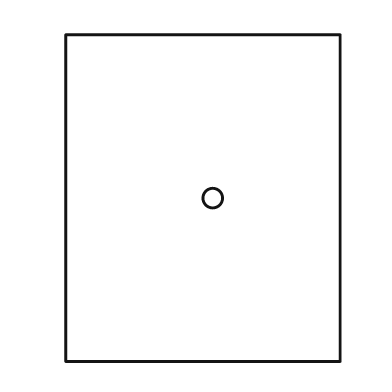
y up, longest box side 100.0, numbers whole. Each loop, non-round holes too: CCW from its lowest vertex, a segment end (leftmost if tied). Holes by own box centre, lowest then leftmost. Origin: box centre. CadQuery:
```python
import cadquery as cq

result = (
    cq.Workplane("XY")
    .moveTo(-42.0, -50.0)
    .lineTo(42.0, -50.0)
    .lineTo(42.0, 50.0)
    .lineTo(-42.0, 50.0)
    .close()
    .moveTo(3.0, 0.0)
    .circle(3.0)
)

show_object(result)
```